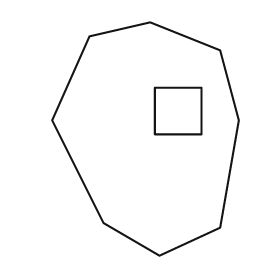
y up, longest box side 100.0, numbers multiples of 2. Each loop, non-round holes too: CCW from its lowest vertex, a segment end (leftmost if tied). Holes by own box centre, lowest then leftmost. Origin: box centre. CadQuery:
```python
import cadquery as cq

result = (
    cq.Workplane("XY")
    .moveTo(6.0, -50.0)
    .lineTo(32.0, -38.0)
    .lineTo(40.0, 8.0)
    .lineTo(32.0, 38.0)
    .lineTo(2.0, 50.0)
    .lineTo(-24.0, 44.0)
    .lineTo(-40.0, 8.0)
    .lineTo(-18.0, -36.0)
    .close()
    .moveTo(4.0, 2.0)
    .lineTo(24.0, 2.0)
    .lineTo(24.0, 22.0)
    .lineTo(4.0, 22.0)
    .close()
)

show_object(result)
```